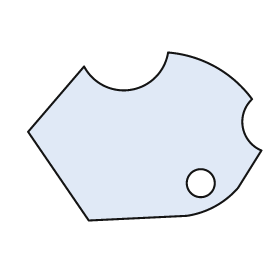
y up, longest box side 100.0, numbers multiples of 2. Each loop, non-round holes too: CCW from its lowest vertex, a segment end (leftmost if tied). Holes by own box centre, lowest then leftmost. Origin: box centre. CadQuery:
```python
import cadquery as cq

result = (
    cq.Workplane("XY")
    .moveTo(-24.0, -36.0)
    .lineTo(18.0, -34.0)
    .threePointArc((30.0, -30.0), (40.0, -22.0))
    .lineTo(50.0, -6.0)
    .threePointArc((42.0, 4.0), (46.0, 16.0))
    .threePointArc((30.0, 30.0), (10.0, 36.0))
    .threePointArc((-6.0, 20.0), (-26.0, 30.0))
    .lineTo(-50.0, 2.0)
    .close()
    .moveTo(24.0, -20.0)
    .circle(6.0)
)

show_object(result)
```